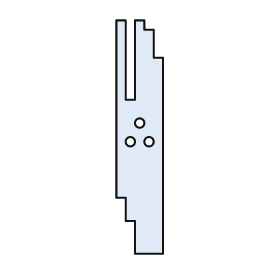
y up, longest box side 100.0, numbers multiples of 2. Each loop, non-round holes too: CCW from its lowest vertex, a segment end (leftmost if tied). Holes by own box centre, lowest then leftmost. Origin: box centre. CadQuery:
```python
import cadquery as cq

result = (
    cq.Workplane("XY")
    .moveTo(-2.0, -50.0)
    .lineTo(10.0, -50.0)
    .lineTo(10.0, 34.0)
    .lineTo(6.0, 34.0)
    .lineTo(6.0, 46.0)
    .lineTo(2.0, 46.0)
    .lineTo(2.0, 50.0)
    .lineTo(-2.0, 50.0)
    .lineTo(-2.0, 16.0)
    .lineTo(-6.0, 16.0)
    .lineTo(-6.0, 50.0)
    .lineTo(-10.0, 50.0)
    .lineTo(-10.0, -26.0)
    .lineTo(-6.0, -26.0)
    .lineTo(-6.0, -36.0)
    .lineTo(-2.0, -36.0)
    .close()
    .moveTo(-4.0, -2.0)
    .circle(2.0)
    .moveTo(4.0, -2.0)
    .circle(2.0)
    .moveTo(0.0, 6.0)
    .circle(2.0)
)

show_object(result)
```